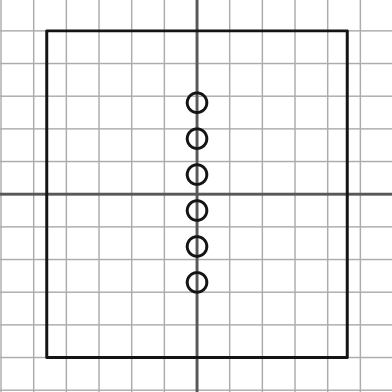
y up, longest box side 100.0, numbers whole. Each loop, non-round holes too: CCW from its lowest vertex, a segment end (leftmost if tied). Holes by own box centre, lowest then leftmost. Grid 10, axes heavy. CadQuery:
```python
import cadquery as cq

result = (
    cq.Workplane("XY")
    .moveTo(-46.0, -50.0)
    .lineTo(46.0, -50.0)
    .lineTo(46.0, 50.0)
    .lineTo(-46.0, 50.0)
    .close()
    .moveTo(0.0, -27.0)
    .circle(3.0)
    .moveTo(0.0, -16.0)
    .circle(3.0)
    .moveTo(0.0, -5.0)
    .circle(3.0)
    .moveTo(0.0, 6.0)
    .circle(3.0)
    .moveTo(0.0, 17.0)
    .circle(3.0)
    .moveTo(0.0, 28.0)
    .circle(3.0)
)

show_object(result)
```